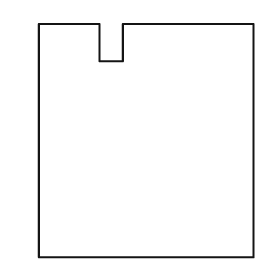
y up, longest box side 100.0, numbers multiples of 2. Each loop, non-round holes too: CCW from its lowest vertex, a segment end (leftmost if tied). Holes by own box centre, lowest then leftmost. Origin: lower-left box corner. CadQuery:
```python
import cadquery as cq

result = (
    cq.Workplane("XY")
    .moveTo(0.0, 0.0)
    .lineTo(92.0, 0.0)
    .lineTo(92.0, 100.0)
    .lineTo(36.0, 100.0)
    .lineTo(36.0, 84.0)
    .lineTo(26.0, 84.0)
    .lineTo(26.0, 100.0)
    .lineTo(0.0, 100.0)
    .close()
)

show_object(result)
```